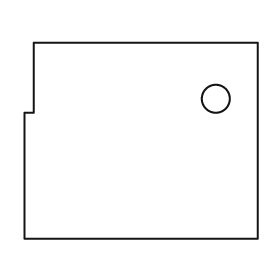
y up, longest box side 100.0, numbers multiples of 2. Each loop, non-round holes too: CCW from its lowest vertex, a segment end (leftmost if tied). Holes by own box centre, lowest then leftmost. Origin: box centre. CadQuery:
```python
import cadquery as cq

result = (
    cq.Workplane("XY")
    .moveTo(-50.0, -42.0)
    .lineTo(50.0, -42.0)
    .lineTo(50.0, 42.0)
    .lineTo(-46.0, 42.0)
    .lineTo(-46.0, 12.0)
    .lineTo(-50.0, 12.0)
    .close()
    .moveTo(32.0, 18.0)
    .circle(6.0)
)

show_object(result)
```